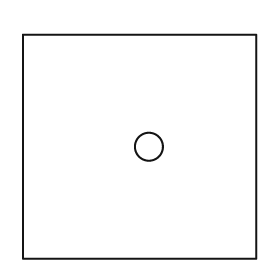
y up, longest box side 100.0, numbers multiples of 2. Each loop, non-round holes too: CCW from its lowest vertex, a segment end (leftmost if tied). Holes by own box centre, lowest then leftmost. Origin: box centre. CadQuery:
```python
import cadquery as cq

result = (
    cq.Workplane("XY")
    .moveTo(-50.0, -48.0)
    .lineTo(50.0, -48.0)
    .lineTo(50.0, 48.0)
    .lineTo(-50.0, 48.0)
    .close()
    .moveTo(4.0, 0.0)
    .circle(6.0)
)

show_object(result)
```